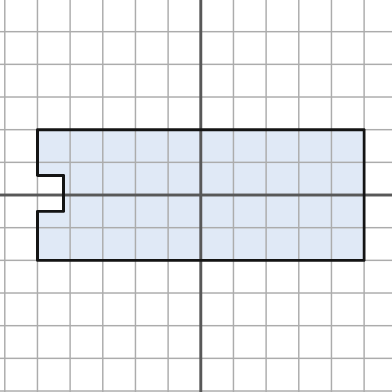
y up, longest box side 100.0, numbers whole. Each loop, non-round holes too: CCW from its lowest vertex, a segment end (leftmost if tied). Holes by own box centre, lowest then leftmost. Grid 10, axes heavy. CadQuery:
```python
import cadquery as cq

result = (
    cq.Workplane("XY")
    .moveTo(-50.0, -20.0)
    .lineTo(50.0, -20.0)
    .lineTo(50.0, 20.0)
    .lineTo(-50.0, 20.0)
    .lineTo(-50.0, 6.0)
    .lineTo(-42.0, 6.0)
    .lineTo(-42.0, -5.0)
    .lineTo(-50.0, -5.0)
    .close()
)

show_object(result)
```